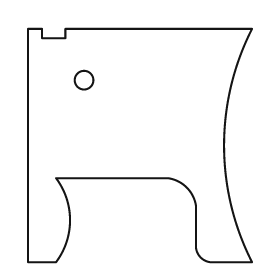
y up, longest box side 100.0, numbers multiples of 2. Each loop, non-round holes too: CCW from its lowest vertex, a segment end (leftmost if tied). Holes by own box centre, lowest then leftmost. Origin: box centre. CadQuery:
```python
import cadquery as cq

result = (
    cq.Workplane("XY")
    .moveTo(-48.0, -50.0)
    .lineTo(-36.0, -50.0)
    .threePointArc((-30.0, -32.0), (-36.0, -14.0))
    .lineTo(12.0, -14.0)
    .threePointArc((20.0, -18.0), (24.0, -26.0))
    .lineTo(24.0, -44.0)
    .threePointArc((26.0, -48.0), (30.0, -50.0))
    .lineTo(48.0, -50.0)
    .threePointArc((36.0, 0.0), (48.0, 50.0))
    .lineTo(-32.0, 50.0)
    .lineTo(-32.0, 46.0)
    .lineTo(-42.0, 46.0)
    .lineTo(-42.0, 50.0)
    .lineTo(-48.0, 50.0)
    .close()
    .moveTo(-24.0, 28.0)
    .circle(4.0)
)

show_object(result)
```